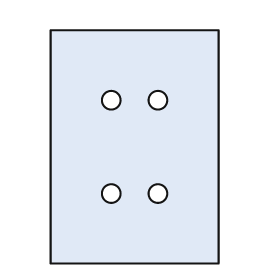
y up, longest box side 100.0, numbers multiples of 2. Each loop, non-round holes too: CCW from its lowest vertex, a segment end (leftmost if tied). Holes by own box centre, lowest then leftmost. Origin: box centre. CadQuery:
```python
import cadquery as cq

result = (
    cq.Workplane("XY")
    .moveTo(-36.0, -50.0)
    .lineTo(36.0, -50.0)
    .lineTo(36.0, 50.0)
    .lineTo(-36.0, 50.0)
    .close()
    .moveTo(-10.0, -20.0)
    .circle(4.0)
    .moveTo(10.0, -20.0)
    .circle(4.0)
    .moveTo(-10.0, 20.0)
    .circle(4.0)
    .moveTo(10.0, 20.0)
    .circle(4.0)
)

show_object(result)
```